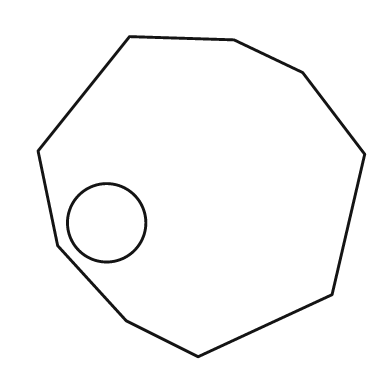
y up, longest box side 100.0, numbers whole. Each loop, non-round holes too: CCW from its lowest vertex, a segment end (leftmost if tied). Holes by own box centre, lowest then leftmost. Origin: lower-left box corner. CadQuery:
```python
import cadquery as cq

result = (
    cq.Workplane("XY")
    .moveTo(49.0, 0.0)
    .lineTo(90.0, 19.0)
    .lineTo(100.0, 62.0)
    .lineTo(81.0, 87.0)
    .lineTo(60.0, 97.0)
    .lineTo(28.0, 98.0)
    .lineTo(0.0, 63.0)
    .lineTo(6.0, 34.0)
    .lineTo(27.0, 11.0)
    .close()
    .moveTo(21.0, 41.0)
    .circle(12.0)
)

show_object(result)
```